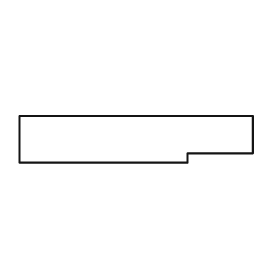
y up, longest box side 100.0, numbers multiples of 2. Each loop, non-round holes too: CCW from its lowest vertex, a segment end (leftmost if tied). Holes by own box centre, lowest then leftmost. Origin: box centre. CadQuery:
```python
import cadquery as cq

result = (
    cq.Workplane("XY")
    .moveTo(-50.0, -10.0)
    .lineTo(22.0, -10.0)
    .lineTo(22.0, -6.0)
    .lineTo(50.0, -6.0)
    .lineTo(50.0, 10.0)
    .lineTo(-50.0, 10.0)
    .close()
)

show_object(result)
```